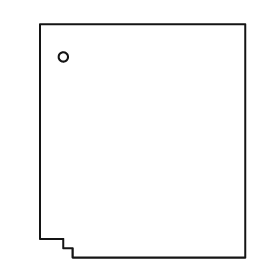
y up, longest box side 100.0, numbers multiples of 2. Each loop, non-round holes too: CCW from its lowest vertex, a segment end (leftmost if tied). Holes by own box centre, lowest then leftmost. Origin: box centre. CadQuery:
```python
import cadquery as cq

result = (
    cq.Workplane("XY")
    .moveTo(-30.0, -50.0)
    .lineTo(44.0, -50.0)
    .lineTo(44.0, 50.0)
    .lineTo(-44.0, 50.0)
    .lineTo(-44.0, -42.0)
    .lineTo(-34.0, -42.0)
    .lineTo(-34.0, -46.0)
    .lineTo(-30.0, -46.0)
    .close()
    .moveTo(-34.0, 36.0)
    .circle(2.0)
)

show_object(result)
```